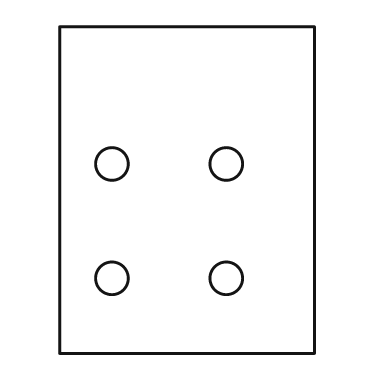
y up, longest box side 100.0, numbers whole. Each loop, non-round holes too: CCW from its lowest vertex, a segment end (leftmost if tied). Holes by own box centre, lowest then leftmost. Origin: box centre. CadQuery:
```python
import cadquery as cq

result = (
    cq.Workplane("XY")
    .moveTo(-39.0, -50.0)
    .lineTo(39.0, -50.0)
    .lineTo(39.0, 50.0)
    .lineTo(-39.0, 50.0)
    .close()
    .moveTo(-23.0, -27.0)
    .circle(5.0)
    .moveTo(12.0, -27.0)
    .circle(5.0)
    .moveTo(-23.0, 8.0)
    .circle(5.0)
    .moveTo(12.0, 8.0)
    .circle(5.0)
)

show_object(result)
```